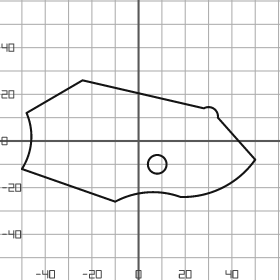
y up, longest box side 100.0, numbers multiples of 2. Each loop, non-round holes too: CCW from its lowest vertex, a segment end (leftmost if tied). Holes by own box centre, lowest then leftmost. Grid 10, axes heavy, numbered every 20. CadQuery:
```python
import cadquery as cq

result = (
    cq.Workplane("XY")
    .moveTo(-10.0, -26.0)
    .threePointArc((4.0, -22.0), (18.0, -24.0))
    .threePointArc((36.0, -20.0), (50.0, -8.0))
    .lineTo(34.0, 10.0)
    .threePointArc((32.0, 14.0), (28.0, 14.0))
    .lineTo(-24.0, 26.0)
    .lineTo(-48.0, 12.0)
    .threePointArc((-46.0, 0.0), (-50.0, -12.0))
    .close()
    .moveTo(8.0, -10.0)
    .circle(4.0)
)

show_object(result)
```